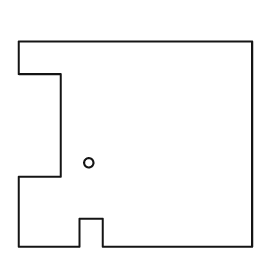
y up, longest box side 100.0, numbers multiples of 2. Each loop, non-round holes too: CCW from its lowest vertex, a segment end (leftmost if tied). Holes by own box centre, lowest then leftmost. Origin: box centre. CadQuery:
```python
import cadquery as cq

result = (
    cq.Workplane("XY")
    .moveTo(-50.0, -44.0)
    .lineTo(-24.0, -44.0)
    .lineTo(-24.0, -32.0)
    .lineTo(-14.0, -32.0)
    .lineTo(-14.0, -44.0)
    .lineTo(50.0, -44.0)
    .lineTo(50.0, 44.0)
    .lineTo(-50.0, 44.0)
    .lineTo(-50.0, 30.0)
    .lineTo(-32.0, 30.0)
    .lineTo(-32.0, -14.0)
    .lineTo(-50.0, -14.0)
    .close()
    .moveTo(-20.0, -8.0)
    .circle(2.0)
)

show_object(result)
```